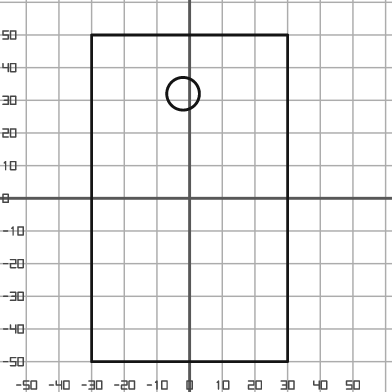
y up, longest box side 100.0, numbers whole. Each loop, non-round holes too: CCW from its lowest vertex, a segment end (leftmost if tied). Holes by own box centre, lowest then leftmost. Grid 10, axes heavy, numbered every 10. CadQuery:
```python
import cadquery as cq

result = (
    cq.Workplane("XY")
    .moveTo(-30.0, -50.0)
    .lineTo(30.0, -50.0)
    .lineTo(30.0, 50.0)
    .lineTo(-30.0, 50.0)
    .close()
    .moveTo(-2.0, 32.0)
    .circle(5.0)
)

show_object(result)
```